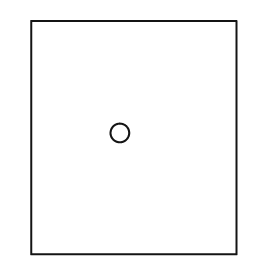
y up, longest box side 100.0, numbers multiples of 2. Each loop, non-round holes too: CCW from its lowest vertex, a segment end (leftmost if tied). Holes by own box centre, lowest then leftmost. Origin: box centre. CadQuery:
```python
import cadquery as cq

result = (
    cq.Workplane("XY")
    .moveTo(-44.0, -50.0)
    .lineTo(44.0, -50.0)
    .lineTo(44.0, 50.0)
    .lineTo(-44.0, 50.0)
    .close()
    .moveTo(-6.0, 2.0)
    .circle(4.0)
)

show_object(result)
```